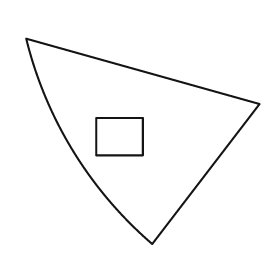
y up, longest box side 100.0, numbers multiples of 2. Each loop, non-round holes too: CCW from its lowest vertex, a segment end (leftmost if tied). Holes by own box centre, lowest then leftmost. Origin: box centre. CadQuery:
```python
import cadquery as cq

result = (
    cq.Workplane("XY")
    .moveTo(4.0, -44.0)
    .lineTo(50.0, 16.0)
    .lineTo(-50.0, 44.0)
    .threePointArc((-30.0, -4.0), (4.0, -44.0))
    .close()
    .moveTo(-20.0, -6.0)
    .lineTo(0.0, -6.0)
    .lineTo(0.0, 10.0)
    .lineTo(-20.0, 10.0)
    .close()
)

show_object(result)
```